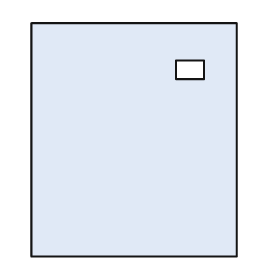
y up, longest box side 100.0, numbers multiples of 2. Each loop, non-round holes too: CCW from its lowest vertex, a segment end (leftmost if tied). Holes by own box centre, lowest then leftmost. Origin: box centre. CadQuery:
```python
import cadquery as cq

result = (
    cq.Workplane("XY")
    .moveTo(-44.0, -50.0)
    .lineTo(44.0, -50.0)
    .lineTo(44.0, 50.0)
    .lineTo(-44.0, 50.0)
    .close()
    .moveTo(18.0, 26.0)
    .lineTo(30.0, 26.0)
    .lineTo(30.0, 34.0)
    .lineTo(18.0, 34.0)
    .close()
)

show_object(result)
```